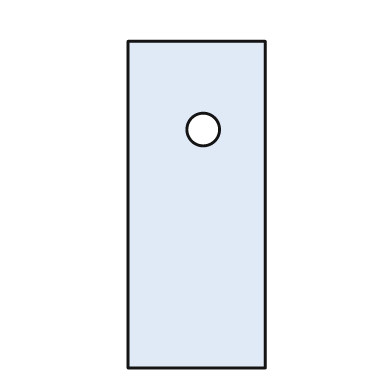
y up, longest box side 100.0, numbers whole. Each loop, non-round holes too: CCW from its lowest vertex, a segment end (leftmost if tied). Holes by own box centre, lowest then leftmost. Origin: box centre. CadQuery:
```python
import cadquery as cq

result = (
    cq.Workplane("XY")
    .moveTo(-21.0, -50.0)
    .lineTo(21.0, -50.0)
    .lineTo(21.0, 50.0)
    .lineTo(-21.0, 50.0)
    .close()
    .moveTo(2.0, 23.0)
    .circle(5.0)
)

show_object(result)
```